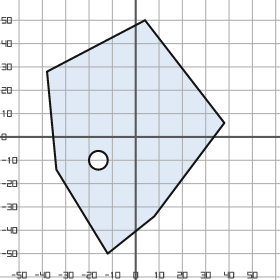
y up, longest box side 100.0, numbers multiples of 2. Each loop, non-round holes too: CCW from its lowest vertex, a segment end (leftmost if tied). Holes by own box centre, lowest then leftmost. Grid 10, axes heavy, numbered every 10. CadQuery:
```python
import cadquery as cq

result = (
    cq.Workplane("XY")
    .moveTo(-12.0, -50.0)
    .lineTo(8.0, -34.0)
    .lineTo(38.0, 6.0)
    .lineTo(4.0, 50.0)
    .lineTo(-38.0, 28.0)
    .lineTo(-34.0, -14.0)
    .close()
    .moveTo(-16.0, -10.0)
    .circle(4.0)
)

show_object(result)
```